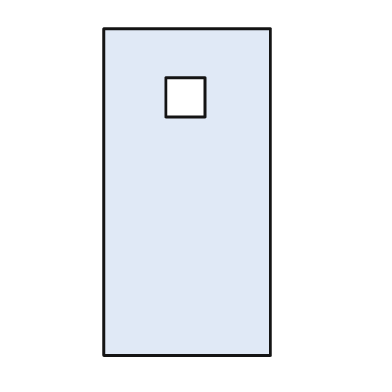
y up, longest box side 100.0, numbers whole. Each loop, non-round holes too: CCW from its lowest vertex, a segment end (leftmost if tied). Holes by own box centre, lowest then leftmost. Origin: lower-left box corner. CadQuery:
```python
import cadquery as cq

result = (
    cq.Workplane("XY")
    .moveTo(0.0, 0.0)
    .lineTo(51.0, 0.0)
    .lineTo(51.0, 100.0)
    .lineTo(0.0, 100.0)
    .close()
    .moveTo(19.0, 73.0)
    .lineTo(31.0, 73.0)
    .lineTo(31.0, 85.0)
    .lineTo(19.0, 85.0)
    .close()
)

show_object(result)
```